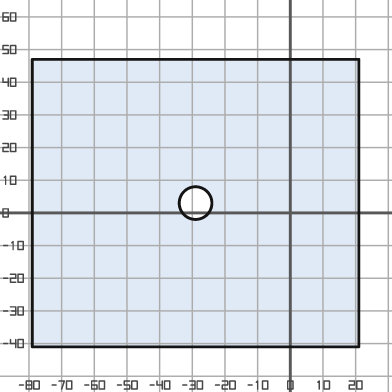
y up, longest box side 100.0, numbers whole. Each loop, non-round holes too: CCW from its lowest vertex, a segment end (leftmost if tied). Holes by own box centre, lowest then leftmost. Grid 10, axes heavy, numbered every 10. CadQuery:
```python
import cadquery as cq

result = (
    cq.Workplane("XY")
    .moveTo(-79.0, -41.0)
    .lineTo(21.0, -41.0)
    .lineTo(21.0, 47.0)
    .lineTo(-79.0, 47.0)
    .close()
    .moveTo(-29.0, 3.0)
    .circle(5.0)
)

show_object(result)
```